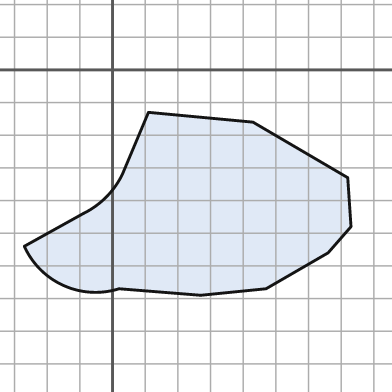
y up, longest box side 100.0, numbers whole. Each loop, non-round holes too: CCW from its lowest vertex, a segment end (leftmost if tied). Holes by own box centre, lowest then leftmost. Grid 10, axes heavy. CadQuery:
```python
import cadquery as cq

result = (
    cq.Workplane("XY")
    .moveTo(27.0, -69.0)
    .lineTo(47.0, -67.0)
    .lineTo(66.0, -56.0)
    .lineTo(73.0, -48.0)
    .lineTo(72.0, -33.0)
    .lineTo(43.0, -16.0)
    .lineTo(11.0, -13.0)
    .lineTo(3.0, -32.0)
    .threePointArc((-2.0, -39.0), (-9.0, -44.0))
    .lineTo(-27.0, -54.0)
    .threePointArc((-15.0, -66.0), (2.0, -67.0))
    .close()
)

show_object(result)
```